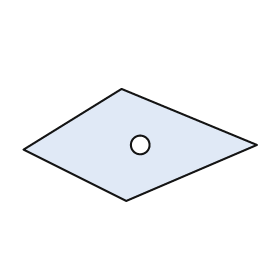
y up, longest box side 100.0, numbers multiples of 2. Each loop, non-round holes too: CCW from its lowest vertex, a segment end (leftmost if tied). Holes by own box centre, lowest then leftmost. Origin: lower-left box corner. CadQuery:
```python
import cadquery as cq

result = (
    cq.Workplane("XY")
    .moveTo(44.0, 0.0)
    .lineTo(100.0, 24.0)
    .lineTo(42.0, 48.0)
    .lineTo(0.0, 22.0)
    .close()
    .moveTo(50.0, 24.0)
    .circle(4.0)
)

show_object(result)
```